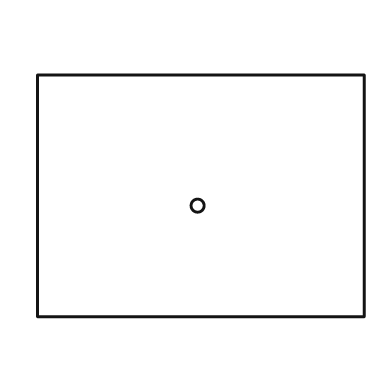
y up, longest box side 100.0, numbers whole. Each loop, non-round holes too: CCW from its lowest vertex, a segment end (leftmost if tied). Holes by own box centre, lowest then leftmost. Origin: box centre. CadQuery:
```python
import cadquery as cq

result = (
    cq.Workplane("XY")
    .moveTo(-50.0, -37.0)
    .lineTo(50.0, -37.0)
    .lineTo(50.0, 37.0)
    .lineTo(-50.0, 37.0)
    .close()
    .moveTo(-1.0, -3.0)
    .circle(2.0)
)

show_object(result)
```